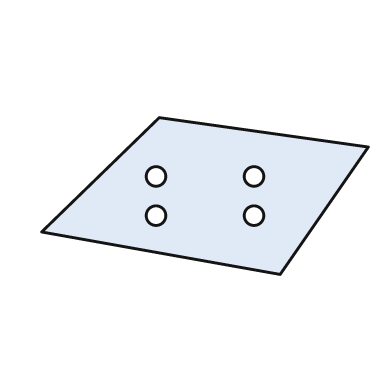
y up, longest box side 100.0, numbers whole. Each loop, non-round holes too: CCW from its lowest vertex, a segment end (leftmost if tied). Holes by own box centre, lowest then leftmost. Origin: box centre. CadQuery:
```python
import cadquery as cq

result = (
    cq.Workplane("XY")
    .moveTo(23.0, -24.0)
    .lineTo(50.0, 15.0)
    .lineTo(-14.0, 24.0)
    .lineTo(-50.0, -11.0)
    .close()
    .moveTo(-15.0, -6.0)
    .circle(3.0)
    .moveTo(15.0, -6.0)
    .circle(3.0)
    .moveTo(-15.0, 6.0)
    .circle(3.0)
    .moveTo(15.0, 6.0)
    .circle(3.0)
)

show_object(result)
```